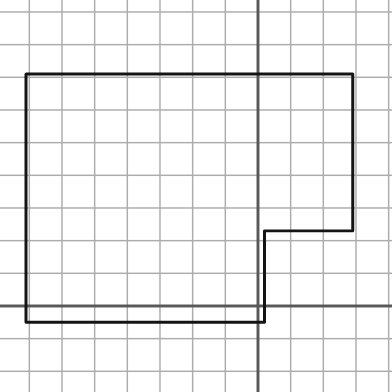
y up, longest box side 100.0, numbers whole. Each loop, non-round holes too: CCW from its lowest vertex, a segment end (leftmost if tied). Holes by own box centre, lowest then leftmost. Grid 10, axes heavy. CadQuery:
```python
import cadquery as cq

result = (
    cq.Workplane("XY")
    .moveTo(-71.0, -5.0)
    .lineTo(2.0, -5.0)
    .lineTo(2.0, 23.0)
    .lineTo(29.0, 23.0)
    .lineTo(29.0, 71.0)
    .lineTo(-71.0, 71.0)
    .close()
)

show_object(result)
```